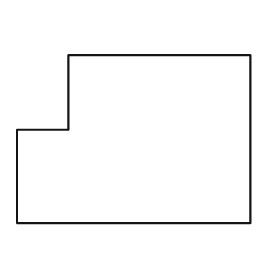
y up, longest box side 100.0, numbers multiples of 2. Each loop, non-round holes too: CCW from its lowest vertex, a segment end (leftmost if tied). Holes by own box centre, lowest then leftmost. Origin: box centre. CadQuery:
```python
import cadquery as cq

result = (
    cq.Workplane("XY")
    .moveTo(-50.0, -36.0)
    .lineTo(50.0, -36.0)
    .lineTo(50.0, 36.0)
    .lineTo(-28.0, 36.0)
    .lineTo(-28.0, 4.0)
    .lineTo(-50.0, 4.0)
    .close()
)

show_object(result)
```